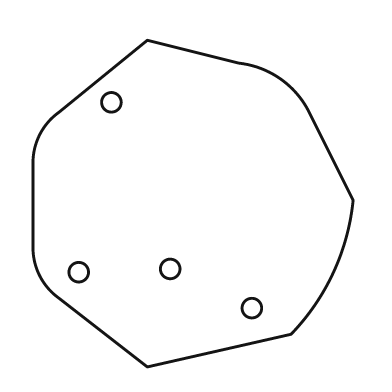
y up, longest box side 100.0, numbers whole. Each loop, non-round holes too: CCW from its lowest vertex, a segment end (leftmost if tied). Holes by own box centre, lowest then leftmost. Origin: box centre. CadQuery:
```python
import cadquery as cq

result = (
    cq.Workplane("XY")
    .moveTo(-14.0, -50.0)
    .lineTo(30.0, -40.0)
    .threePointArc((43.0, -21.0), (49.0, 1.0))
    .lineTo(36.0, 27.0)
    .threePointArc((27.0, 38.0), (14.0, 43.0))
    .lineTo(-14.0, 50.0)
    .lineTo(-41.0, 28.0)
    .threePointArc((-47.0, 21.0), (-49.0, 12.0))
    .lineTo(-49.0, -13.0)
    .threePointArc((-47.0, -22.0), (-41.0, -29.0))
    .close()
    .moveTo(18.0, -32.0)
    .circle(3.0)
    .moveTo(-35.0, -21.0)
    .circle(3.0)
    .moveTo(-7.0, -20.0)
    .circle(3.0)
    .moveTo(-25.0, 31.0)
    .circle(3.0)
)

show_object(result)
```